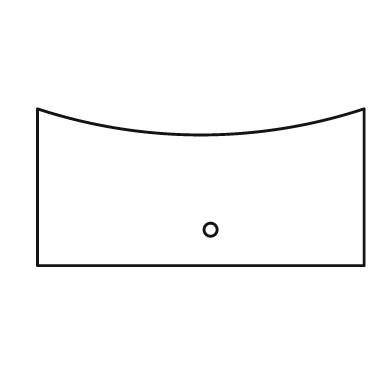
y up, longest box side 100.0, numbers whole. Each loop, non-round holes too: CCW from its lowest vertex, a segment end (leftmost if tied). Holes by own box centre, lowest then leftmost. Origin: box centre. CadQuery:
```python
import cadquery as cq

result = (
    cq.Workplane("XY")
    .moveTo(-50.0, -24.0)
    .lineTo(50.0, -24.0)
    .lineTo(50.0, 24.0)
    .threePointArc((0.0, 16.0), (-50.0, 24.0))
    .close()
    .moveTo(3.0, -13.0)
    .circle(2.0)
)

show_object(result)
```